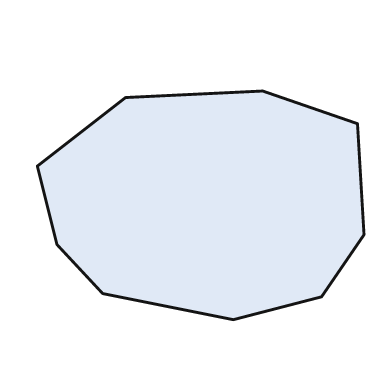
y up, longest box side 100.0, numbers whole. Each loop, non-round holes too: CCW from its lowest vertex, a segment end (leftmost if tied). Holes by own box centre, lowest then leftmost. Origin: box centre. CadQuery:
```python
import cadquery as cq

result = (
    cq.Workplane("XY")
    .moveTo(10.0, -35.0)
    .lineTo(37.0, -28.0)
    .lineTo(50.0, -9.0)
    .lineTo(48.0, 25.0)
    .lineTo(19.0, 35.0)
    .lineTo(-23.0, 33.0)
    .lineTo(-50.0, 12.0)
    .lineTo(-44.0, -12.0)
    .lineTo(-30.0, -27.0)
    .close()
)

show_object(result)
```